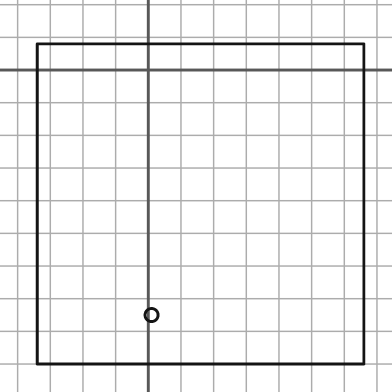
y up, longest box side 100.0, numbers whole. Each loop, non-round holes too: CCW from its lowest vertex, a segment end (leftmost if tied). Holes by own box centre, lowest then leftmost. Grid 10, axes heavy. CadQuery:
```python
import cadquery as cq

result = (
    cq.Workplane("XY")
    .moveTo(-34.0, -90.0)
    .lineTo(66.0, -90.0)
    .lineTo(66.0, 8.0)
    .lineTo(-34.0, 8.0)
    .close()
    .moveTo(1.0, -75.0)
    .circle(2.0)
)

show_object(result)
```